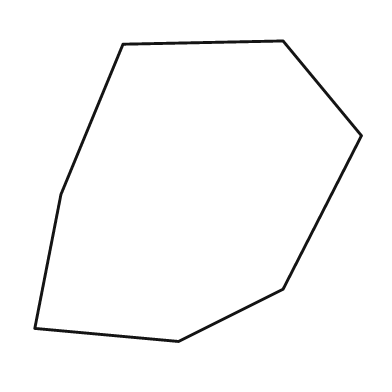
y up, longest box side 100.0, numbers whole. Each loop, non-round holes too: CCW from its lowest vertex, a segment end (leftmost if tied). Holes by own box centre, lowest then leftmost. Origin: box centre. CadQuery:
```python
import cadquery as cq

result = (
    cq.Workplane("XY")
    .moveTo(-6.0, -46.0)
    .lineTo(26.0, -30.0)
    .lineTo(50.0, 17.0)
    .lineTo(26.0, 46.0)
    .lineTo(-23.0, 45.0)
    .lineTo(-42.0, -1.0)
    .lineTo(-50.0, -42.0)
    .close()
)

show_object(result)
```